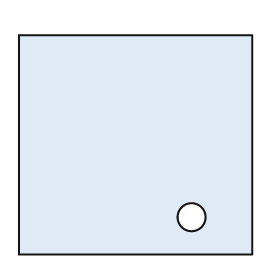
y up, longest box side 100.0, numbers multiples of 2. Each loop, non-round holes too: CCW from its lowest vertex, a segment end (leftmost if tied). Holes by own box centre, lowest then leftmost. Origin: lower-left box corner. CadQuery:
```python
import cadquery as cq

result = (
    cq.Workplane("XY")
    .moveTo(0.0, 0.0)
    .lineTo(100.0, 0.0)
    .lineTo(100.0, 94.0)
    .lineTo(0.0, 94.0)
    .close()
    .moveTo(74.0, 16.0)
    .circle(6.0)
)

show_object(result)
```